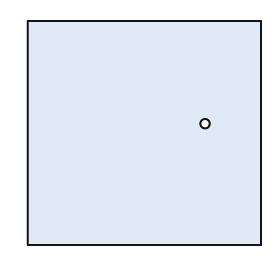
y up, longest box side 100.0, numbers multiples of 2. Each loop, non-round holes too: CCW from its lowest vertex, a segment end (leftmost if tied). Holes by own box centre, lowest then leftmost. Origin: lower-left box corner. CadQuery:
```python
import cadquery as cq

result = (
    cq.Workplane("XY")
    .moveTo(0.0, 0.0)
    .lineTo(100.0, 0.0)
    .lineTo(100.0, 96.0)
    .lineTo(0.0, 96.0)
    .close()
    .moveTo(76.0, 52.0)
    .circle(2.0)
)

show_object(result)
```